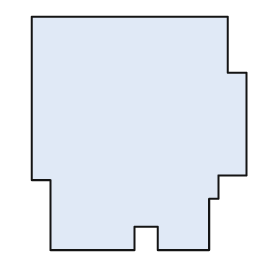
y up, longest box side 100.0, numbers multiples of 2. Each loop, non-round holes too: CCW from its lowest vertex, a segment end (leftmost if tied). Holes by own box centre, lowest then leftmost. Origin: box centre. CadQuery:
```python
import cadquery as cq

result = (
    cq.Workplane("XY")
    .moveTo(-38.0, -50.0)
    .lineTo(-2.0, -50.0)
    .lineTo(-2.0, -40.0)
    .lineTo(8.0, -40.0)
    .lineTo(8.0, -50.0)
    .lineTo(30.0, -50.0)
    .lineTo(30.0, -28.0)
    .lineTo(34.0, -28.0)
    .lineTo(34.0, -18.0)
    .lineTo(46.0, -18.0)
    .lineTo(46.0, 26.0)
    .lineTo(38.0, 26.0)
    .lineTo(38.0, 50.0)
    .lineTo(-46.0, 50.0)
    .lineTo(-46.0, -20.0)
    .lineTo(-38.0, -20.0)
    .close()
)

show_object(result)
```